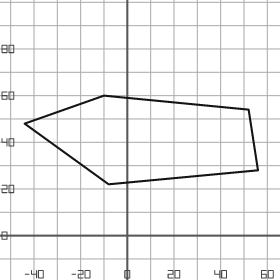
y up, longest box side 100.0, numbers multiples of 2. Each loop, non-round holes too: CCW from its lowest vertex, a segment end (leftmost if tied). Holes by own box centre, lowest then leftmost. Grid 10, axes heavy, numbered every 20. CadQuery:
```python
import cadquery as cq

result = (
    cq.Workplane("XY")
    .moveTo(-8.0, 22.0)
    .lineTo(56.0, 28.0)
    .lineTo(52.0, 54.0)
    .lineTo(-10.0, 60.0)
    .lineTo(-44.0, 48.0)
    .close()
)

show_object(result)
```